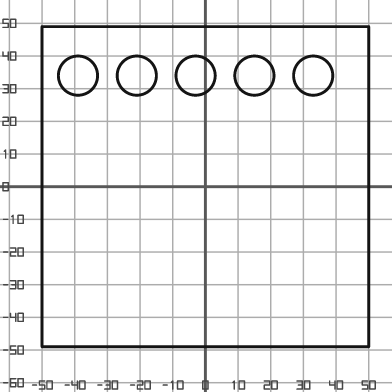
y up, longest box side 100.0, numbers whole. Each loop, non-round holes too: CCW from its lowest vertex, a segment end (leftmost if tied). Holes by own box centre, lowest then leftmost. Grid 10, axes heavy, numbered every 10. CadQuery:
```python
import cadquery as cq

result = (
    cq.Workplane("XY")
    .moveTo(-50.0, -49.0)
    .lineTo(50.0, -49.0)
    .lineTo(50.0, 49.0)
    .lineTo(-50.0, 49.0)
    .close()
    .moveTo(-39.0, 34.0)
    .circle(6.0)
    .moveTo(-21.0, 34.0)
    .circle(6.0)
    .moveTo(-3.0, 34.0)
    .circle(6.0)
    .moveTo(15.0, 34.0)
    .circle(6.0)
    .moveTo(33.0, 34.0)
    .circle(6.0)
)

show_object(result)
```